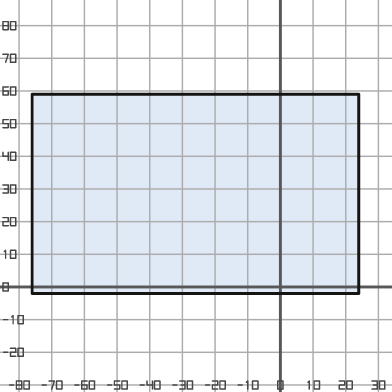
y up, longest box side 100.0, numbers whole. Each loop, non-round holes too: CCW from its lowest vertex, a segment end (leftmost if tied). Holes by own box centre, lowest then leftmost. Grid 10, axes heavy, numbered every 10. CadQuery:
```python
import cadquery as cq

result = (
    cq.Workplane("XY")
    .moveTo(-76.0, -2.0)
    .lineTo(24.0, -2.0)
    .lineTo(24.0, 59.0)
    .lineTo(-76.0, 59.0)
    .close()
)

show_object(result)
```